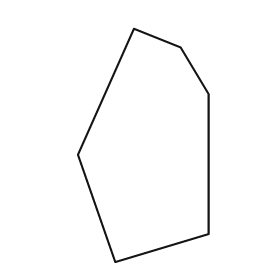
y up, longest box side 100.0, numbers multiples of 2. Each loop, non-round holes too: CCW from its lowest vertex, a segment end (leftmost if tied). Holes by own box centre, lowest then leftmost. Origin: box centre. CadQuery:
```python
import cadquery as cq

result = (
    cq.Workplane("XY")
    .moveTo(-12.0, -50.0)
    .lineTo(28.0, -38.0)
    .lineTo(28.0, 22.0)
    .lineTo(16.0, 42.0)
    .lineTo(-4.0, 50.0)
    .lineTo(-28.0, -4.0)
    .close()
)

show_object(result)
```